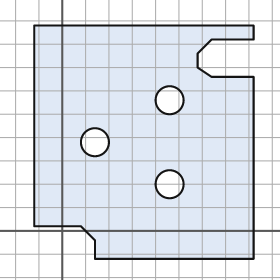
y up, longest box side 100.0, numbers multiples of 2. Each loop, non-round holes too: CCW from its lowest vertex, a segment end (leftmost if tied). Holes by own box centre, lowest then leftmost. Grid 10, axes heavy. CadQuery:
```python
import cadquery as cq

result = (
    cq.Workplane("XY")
    .moveTo(14.0, -12.0)
    .lineTo(82.0, -12.0)
    .lineTo(82.0, 66.0)
    .lineTo(64.0, 66.0)
    .lineTo(58.0, 70.0)
    .lineTo(58.0, 76.0)
    .lineTo(64.0, 82.0)
    .lineTo(82.0, 82.0)
    .lineTo(82.0, 88.0)
    .lineTo(-12.0, 88.0)
    .lineTo(-12.0, 2.0)
    .lineTo(8.0, 2.0)
    .lineTo(14.0, -4.0)
    .close()
    .moveTo(46.0, 20.0)
    .circle(6.0)
    .moveTo(14.0, 38.0)
    .circle(6.0)
    .moveTo(46.0, 56.0)
    .circle(6.0)
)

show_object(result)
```